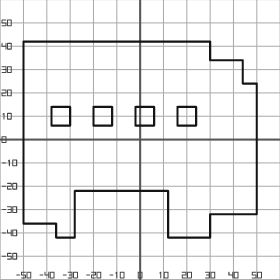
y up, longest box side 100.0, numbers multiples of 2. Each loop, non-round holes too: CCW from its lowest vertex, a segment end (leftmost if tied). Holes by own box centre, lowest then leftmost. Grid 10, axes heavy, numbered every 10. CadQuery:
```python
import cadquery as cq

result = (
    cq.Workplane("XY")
    .moveTo(-36.0, -42.0)
    .lineTo(-28.0, -42.0)
    .lineTo(-28.0, -22.0)
    .lineTo(12.0, -22.0)
    .lineTo(12.0, -42.0)
    .lineTo(30.0, -42.0)
    .lineTo(30.0, -32.0)
    .lineTo(50.0, -32.0)
    .lineTo(50.0, 24.0)
    .lineTo(44.0, 24.0)
    .lineTo(44.0, 34.0)
    .lineTo(30.0, 34.0)
    .lineTo(30.0, 42.0)
    .lineTo(-50.0, 42.0)
    .lineTo(-50.0, -36.0)
    .lineTo(-36.0, -36.0)
    .close()
    .moveTo(-38.0, 6.0)
    .lineTo(-30.0, 6.0)
    .lineTo(-30.0, 14.0)
    .lineTo(-38.0, 14.0)
    .close()
    .moveTo(-20.0, 6.0)
    .lineTo(-12.0, 6.0)
    .lineTo(-12.0, 14.0)
    .lineTo(-20.0, 14.0)
    .close()
    .moveTo(-2.0, 6.0)
    .lineTo(6.0, 6.0)
    .lineTo(6.0, 14.0)
    .lineTo(-2.0, 14.0)
    .close()
    .moveTo(16.0, 6.0)
    .lineTo(24.0, 6.0)
    .lineTo(24.0, 14.0)
    .lineTo(16.0, 14.0)
    .close()
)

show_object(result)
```